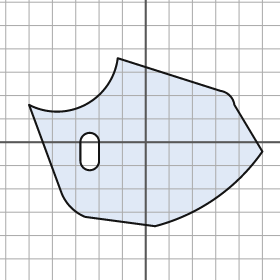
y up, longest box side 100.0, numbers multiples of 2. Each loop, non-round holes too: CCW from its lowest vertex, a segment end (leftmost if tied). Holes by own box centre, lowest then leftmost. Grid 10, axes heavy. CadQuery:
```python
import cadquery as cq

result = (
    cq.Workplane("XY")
    .moveTo(4.0, -36.0)
    .threePointArc((30.0, -24.0), (50.0, -4.0))
    .lineTo(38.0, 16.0)
    .threePointArc((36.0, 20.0), (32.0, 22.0))
    .lineTo(-12.0, 36.0)
    .threePointArc((-26.0, 16.0), (-50.0, 16.0))
    .lineTo(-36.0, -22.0)
    .threePointArc((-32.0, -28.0), (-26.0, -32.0))
    .close()
    .moveTo(-28.0, -8.0)
    .threePointArc((-24.0, -12.0), (-20.0, -8.0))
    .lineTo(-20.0, 0.0)
    .threePointArc((-24.0, 4.0), (-28.0, 0.0))
    .close()
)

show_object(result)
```